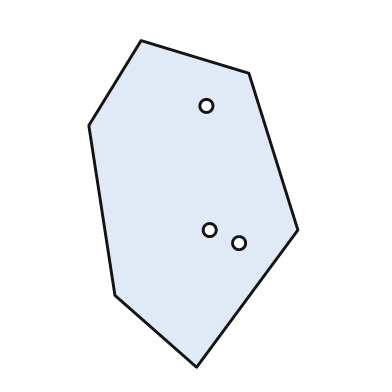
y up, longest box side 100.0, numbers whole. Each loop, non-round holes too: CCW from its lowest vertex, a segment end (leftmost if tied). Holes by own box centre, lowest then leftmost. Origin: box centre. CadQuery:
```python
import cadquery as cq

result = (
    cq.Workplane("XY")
    .moveTo(1.0, -50.0)
    .lineTo(32.0, -8.0)
    .lineTo(17.0, 40.0)
    .lineTo(-16.0, 50.0)
    .lineTo(-32.0, 24.0)
    .lineTo(-24.0, -28.0)
    .close()
    .moveTo(14.0, -12.0)
    .circle(2.0)
    .moveTo(5.0, -8.0)
    .circle(2.0)
    .moveTo(4.0, 30.0)
    .circle(2.0)
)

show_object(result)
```